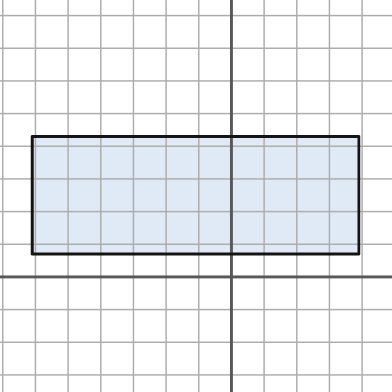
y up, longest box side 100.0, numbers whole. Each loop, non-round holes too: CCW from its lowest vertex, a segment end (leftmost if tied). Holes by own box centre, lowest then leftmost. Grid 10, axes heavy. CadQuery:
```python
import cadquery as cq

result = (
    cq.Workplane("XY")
    .moveTo(-61.0, 7.0)
    .lineTo(39.0, 7.0)
    .lineTo(39.0, 43.0)
    .lineTo(-61.0, 43.0)
    .close()
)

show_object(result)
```